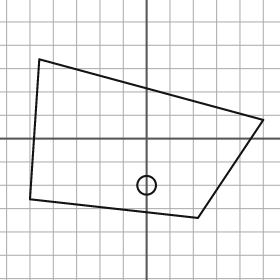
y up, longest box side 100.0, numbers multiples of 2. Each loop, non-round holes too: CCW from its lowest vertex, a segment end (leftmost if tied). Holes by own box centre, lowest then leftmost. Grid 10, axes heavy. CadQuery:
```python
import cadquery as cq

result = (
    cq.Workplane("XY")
    .moveTo(22.0, -34.0)
    .lineTo(50.0, 8.0)
    .lineTo(-46.0, 34.0)
    .lineTo(-50.0, -26.0)
    .close()
    .moveTo(0.0, -20.0)
    .circle(4.0)
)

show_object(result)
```